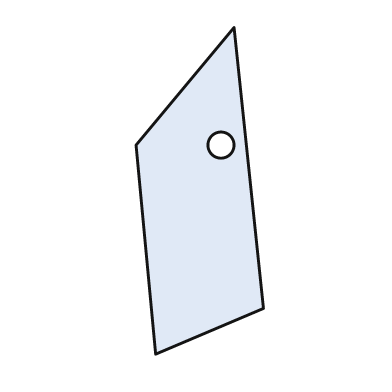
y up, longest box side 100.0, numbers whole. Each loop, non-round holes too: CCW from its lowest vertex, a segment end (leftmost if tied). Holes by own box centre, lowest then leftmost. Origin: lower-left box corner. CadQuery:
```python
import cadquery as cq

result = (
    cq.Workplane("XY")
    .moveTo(6.0, 0.0)
    .lineTo(39.0, 14.0)
    .lineTo(30.0, 100.0)
    .lineTo(0.0, 64.0)
    .close()
    .moveTo(26.0, 64.0)
    .circle(4.0)
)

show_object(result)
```